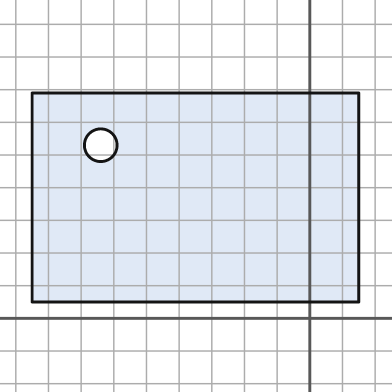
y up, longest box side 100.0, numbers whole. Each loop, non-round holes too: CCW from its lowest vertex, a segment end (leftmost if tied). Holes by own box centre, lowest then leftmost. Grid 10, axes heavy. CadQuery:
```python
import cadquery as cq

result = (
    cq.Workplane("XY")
    .moveTo(-85.0, 5.0)
    .lineTo(15.0, 5.0)
    .lineTo(15.0, 69.0)
    .lineTo(-85.0, 69.0)
    .close()
    .moveTo(-64.0, 53.0)
    .circle(5.0)
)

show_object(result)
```